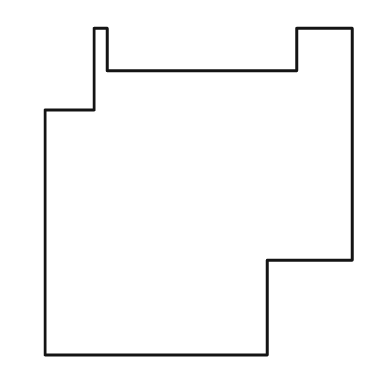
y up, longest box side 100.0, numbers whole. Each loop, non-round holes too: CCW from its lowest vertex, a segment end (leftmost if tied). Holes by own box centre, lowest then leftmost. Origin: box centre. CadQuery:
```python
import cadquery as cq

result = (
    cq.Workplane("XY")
    .moveTo(-47.0, -50.0)
    .lineTo(21.0, -50.0)
    .lineTo(21.0, -21.0)
    .lineTo(47.0, -21.0)
    .lineTo(47.0, 50.0)
    .lineTo(30.0, 50.0)
    .lineTo(30.0, 37.0)
    .lineTo(-28.0, 37.0)
    .lineTo(-28.0, 50.0)
    .lineTo(-32.0, 50.0)
    .lineTo(-32.0, 25.0)
    .lineTo(-47.0, 25.0)
    .close()
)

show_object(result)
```